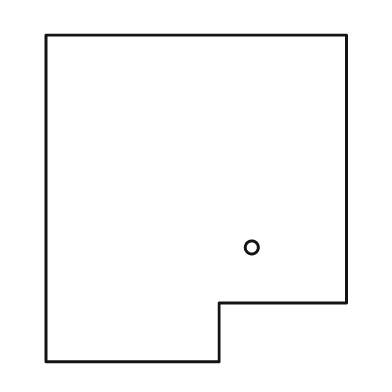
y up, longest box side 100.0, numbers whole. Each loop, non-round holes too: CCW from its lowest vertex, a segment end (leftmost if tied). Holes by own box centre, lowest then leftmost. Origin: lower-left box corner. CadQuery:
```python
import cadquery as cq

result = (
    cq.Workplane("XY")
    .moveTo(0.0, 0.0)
    .lineTo(53.0, 0.0)
    .lineTo(53.0, 18.0)
    .lineTo(92.0, 18.0)
    .lineTo(92.0, 100.0)
    .lineTo(0.0, 100.0)
    .close()
    .moveTo(63.0, 35.0)
    .circle(2.0)
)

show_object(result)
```